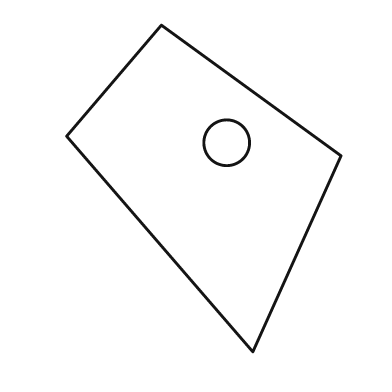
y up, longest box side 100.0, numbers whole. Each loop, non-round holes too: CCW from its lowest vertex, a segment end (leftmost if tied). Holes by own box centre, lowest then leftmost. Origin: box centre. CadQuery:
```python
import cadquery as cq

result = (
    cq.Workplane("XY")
    .moveTo(15.0, -50.0)
    .lineTo(42.0, 10.0)
    .lineTo(-13.0, 50.0)
    .lineTo(-42.0, 16.0)
    .close()
    .moveTo(7.0, 14.0)
    .circle(7.0)
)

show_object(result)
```